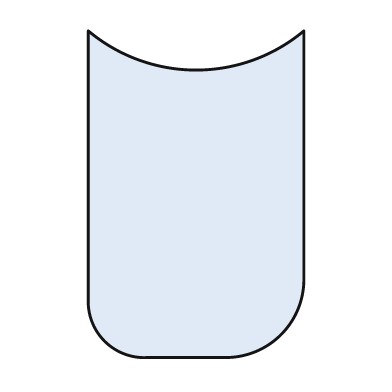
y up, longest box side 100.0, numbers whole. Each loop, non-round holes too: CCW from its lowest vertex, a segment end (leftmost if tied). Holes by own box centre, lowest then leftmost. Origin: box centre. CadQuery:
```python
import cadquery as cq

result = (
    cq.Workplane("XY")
    .moveTo(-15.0, -50.0)
    .lineTo(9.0, -50.0)
    .threePointArc((26.0, -43.0), (33.0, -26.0))
    .lineTo(33.0, 50.0)
    .threePointArc((0.0, 38.0), (-33.0, 50.0))
    .lineTo(-33.0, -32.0)
    .threePointArc((-28.0, -45.0), (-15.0, -50.0))
    .close()
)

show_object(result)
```